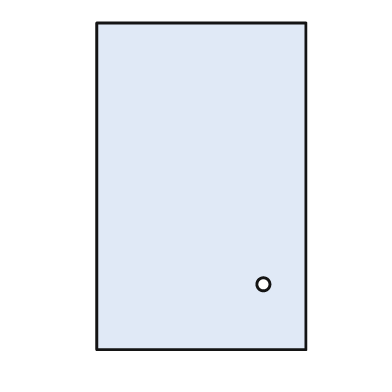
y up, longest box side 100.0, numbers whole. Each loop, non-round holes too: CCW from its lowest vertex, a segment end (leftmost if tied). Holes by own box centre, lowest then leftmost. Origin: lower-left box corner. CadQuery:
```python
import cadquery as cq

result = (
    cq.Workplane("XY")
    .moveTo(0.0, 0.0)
    .lineTo(64.0, 0.0)
    .lineTo(64.0, 100.0)
    .lineTo(0.0, 100.0)
    .close()
    .moveTo(51.0, 20.0)
    .circle(2.0)
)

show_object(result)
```